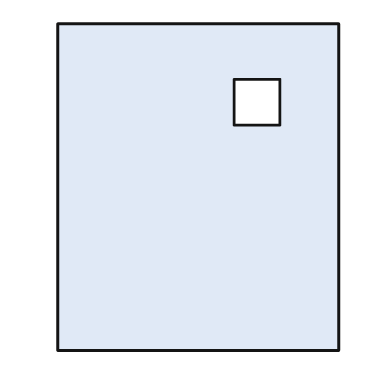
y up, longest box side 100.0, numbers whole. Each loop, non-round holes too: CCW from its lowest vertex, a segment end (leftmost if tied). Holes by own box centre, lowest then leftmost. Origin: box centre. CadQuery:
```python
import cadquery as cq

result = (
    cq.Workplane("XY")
    .moveTo(-43.0, -50.0)
    .lineTo(43.0, -50.0)
    .lineTo(43.0, 50.0)
    .lineTo(-43.0, 50.0)
    .close()
    .moveTo(11.0, 19.0)
    .lineTo(25.0, 19.0)
    .lineTo(25.0, 33.0)
    .lineTo(11.0, 33.0)
    .close()
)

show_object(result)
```